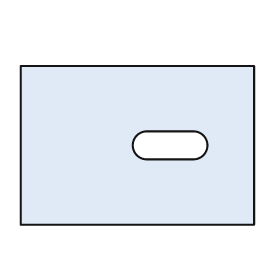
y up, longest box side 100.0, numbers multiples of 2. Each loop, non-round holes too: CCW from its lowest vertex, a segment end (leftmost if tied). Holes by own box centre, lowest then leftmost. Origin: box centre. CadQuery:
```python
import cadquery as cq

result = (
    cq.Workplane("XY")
    .moveTo(-50.0, -34.0)
    .lineTo(50.0, -34.0)
    .lineTo(50.0, 34.0)
    .lineTo(-50.0, 34.0)
    .close()
    .moveTo(4.0, -6.0)
    .lineTo(24.0, -6.0)
    .threePointArc((30.0, 0.0), (24.0, 6.0))
    .lineTo(4.0, 6.0)
    .threePointArc((-2.0, 0.0), (4.0, -6.0))
    .close()
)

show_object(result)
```